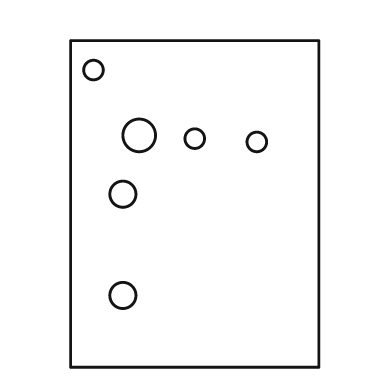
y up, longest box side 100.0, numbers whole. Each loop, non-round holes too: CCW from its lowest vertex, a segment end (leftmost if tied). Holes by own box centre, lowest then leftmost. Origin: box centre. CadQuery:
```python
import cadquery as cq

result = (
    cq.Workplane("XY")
    .moveTo(-38.0, -50.0)
    .lineTo(38.0, -50.0)
    .lineTo(38.0, 50.0)
    .lineTo(-38.0, 50.0)
    .close()
    .moveTo(-22.0, -28.0)
    .circle(4.0)
    .moveTo(-22.0, 3.0)
    .circle(4.0)
    .moveTo(19.0, 19.0)
    .circle(3.0)
    .moveTo(0.0, 20.0)
    .circle(3.0)
    .moveTo(-17.0, 21.0)
    .circle(5.0)
    .moveTo(-31.0, 41.0)
    .circle(3.0)
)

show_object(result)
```